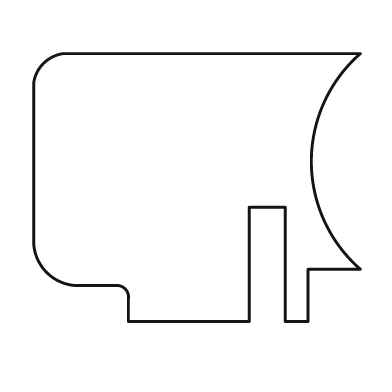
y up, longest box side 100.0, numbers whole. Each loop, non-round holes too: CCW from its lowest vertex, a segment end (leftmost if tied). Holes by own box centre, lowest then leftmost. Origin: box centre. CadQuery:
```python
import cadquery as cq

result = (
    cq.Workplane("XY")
    .moveTo(-21.0, -41.0)
    .lineTo(16.0, -41.0)
    .lineTo(16.0, -6.0)
    .lineTo(27.0, -6.0)
    .lineTo(27.0, -41.0)
    .lineTo(34.0, -41.0)
    .lineTo(34.0, -25.0)
    .lineTo(50.0, -25.0)
    .threePointArc((35.0, 8.0), (50.0, 41.0))
    .lineTo(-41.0, 41.0)
    .threePointArc((-47.0, 38.0), (-50.0, 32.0))
    .lineTo(-50.0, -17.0)
    .threePointArc((-46.0, -26.0), (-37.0, -30.0))
    .lineTo(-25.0, -30.0)
    .threePointArc((-22.0, -31.0), (-21.0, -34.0))
    .close()
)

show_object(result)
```